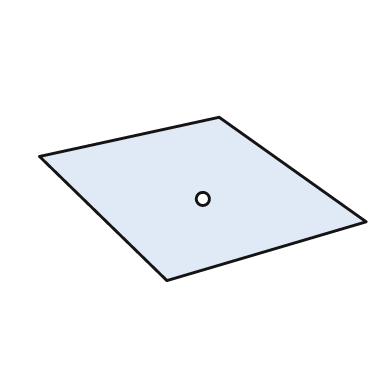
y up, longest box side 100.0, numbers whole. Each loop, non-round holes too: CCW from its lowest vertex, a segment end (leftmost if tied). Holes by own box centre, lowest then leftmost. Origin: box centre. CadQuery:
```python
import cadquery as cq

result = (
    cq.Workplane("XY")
    .moveTo(-11.0, -25.0)
    .lineTo(50.0, -7.0)
    .lineTo(5.0, 25.0)
    .lineTo(-50.0, 13.0)
    .close()
    .moveTo(0.0, 0.0)
    .circle(2.0)
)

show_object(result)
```